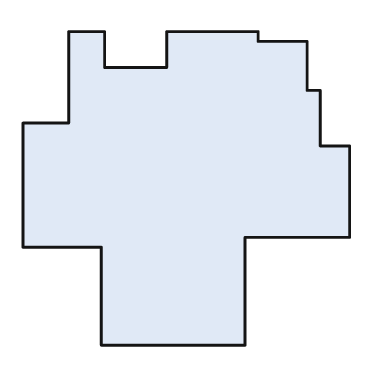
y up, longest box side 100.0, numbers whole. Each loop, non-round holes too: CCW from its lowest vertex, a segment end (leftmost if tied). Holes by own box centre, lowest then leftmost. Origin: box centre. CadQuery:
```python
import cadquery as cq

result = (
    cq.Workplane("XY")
    .moveTo(-26.0, -48.0)
    .lineTo(18.0, -48.0)
    .lineTo(18.0, -15.0)
    .lineTo(50.0, -15.0)
    .lineTo(50.0, 13.0)
    .lineTo(41.0, 13.0)
    .lineTo(41.0, 30.0)
    .lineTo(37.0, 30.0)
    .lineTo(37.0, 45.0)
    .lineTo(22.0, 45.0)
    .lineTo(22.0, 48.0)
    .lineTo(-6.0, 48.0)
    .lineTo(-6.0, 37.0)
    .lineTo(-25.0, 37.0)
    .lineTo(-25.0, 48.0)
    .lineTo(-36.0, 48.0)
    .lineTo(-36.0, 20.0)
    .lineTo(-50.0, 20.0)
    .lineTo(-50.0, -18.0)
    .lineTo(-26.0, -18.0)
    .close()
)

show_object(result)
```